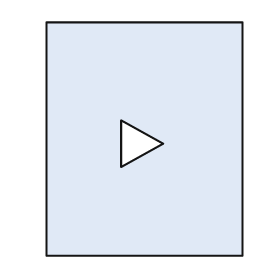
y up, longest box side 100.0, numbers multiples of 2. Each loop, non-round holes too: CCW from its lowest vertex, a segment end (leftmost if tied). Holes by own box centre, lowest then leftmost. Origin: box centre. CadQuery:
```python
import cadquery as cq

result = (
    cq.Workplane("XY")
    .moveTo(-42.0, -50.0)
    .lineTo(42.0, -50.0)
    .lineTo(42.0, 50.0)
    .lineTo(-42.0, 50.0)
    .close()
    .moveTo(-10.0, -12.0)
    .lineTo(8.0, -2.0)
    .lineTo(-10.0, 8.0)
    .close()
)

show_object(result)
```